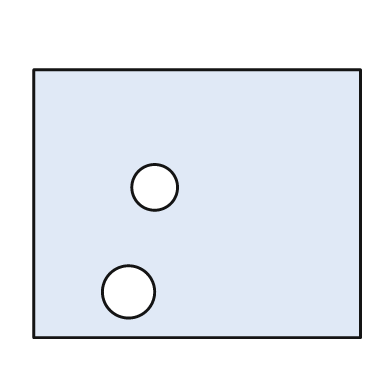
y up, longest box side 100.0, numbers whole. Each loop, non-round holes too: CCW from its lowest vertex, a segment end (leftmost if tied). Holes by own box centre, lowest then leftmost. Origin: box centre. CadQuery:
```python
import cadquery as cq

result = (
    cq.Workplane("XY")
    .moveTo(-50.0, -41.0)
    .lineTo(50.0, -41.0)
    .lineTo(50.0, 41.0)
    .lineTo(-50.0, 41.0)
    .close()
    .moveTo(-21.0, -27.0)
    .circle(8.0)
    .moveTo(-13.0, 5.0)
    .circle(7.0)
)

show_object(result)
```